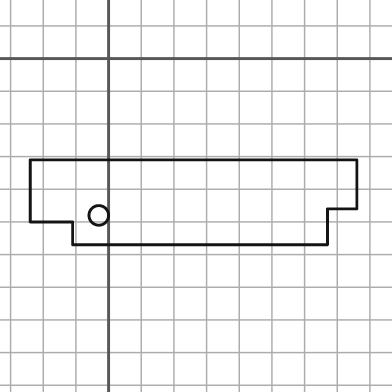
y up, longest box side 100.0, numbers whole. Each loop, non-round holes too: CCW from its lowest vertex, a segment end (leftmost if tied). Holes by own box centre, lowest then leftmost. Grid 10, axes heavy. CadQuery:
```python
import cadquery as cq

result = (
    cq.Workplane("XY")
    .moveTo(-11.0, -57.0)
    .lineTo(67.0, -57.0)
    .lineTo(67.0, -46.0)
    .lineTo(76.0, -46.0)
    .lineTo(76.0, -31.0)
    .lineTo(-24.0, -31.0)
    .lineTo(-24.0, -50.0)
    .lineTo(-11.0, -50.0)
    .close()
    .moveTo(-3.0, -48.0)
    .circle(3.0)
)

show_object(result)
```